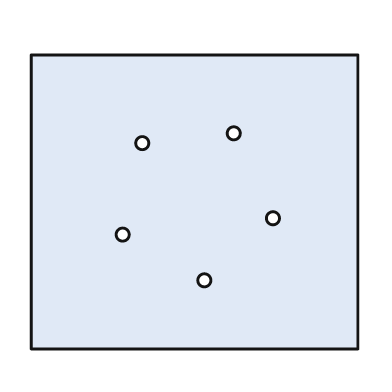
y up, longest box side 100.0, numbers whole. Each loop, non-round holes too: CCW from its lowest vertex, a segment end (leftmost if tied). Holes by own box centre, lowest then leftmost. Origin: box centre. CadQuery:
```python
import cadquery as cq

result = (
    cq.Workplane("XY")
    .moveTo(-50.0, -45.0)
    .lineTo(50.0, -45.0)
    .lineTo(50.0, 45.0)
    .lineTo(-50.0, 45.0)
    .close()
    .moveTo(3.0, -24.0)
    .circle(2.0)
    .moveTo(-22.0, -10.0)
    .circle(2.0)
    .moveTo(24.0, -5.0)
    .circle(2.0)
    .moveTo(-16.0, 18.0)
    .circle(2.0)
    .moveTo(12.0, 21.0)
    .circle(2.0)
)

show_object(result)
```